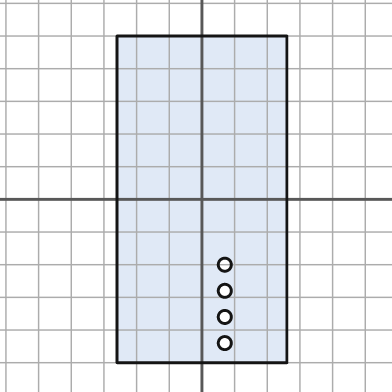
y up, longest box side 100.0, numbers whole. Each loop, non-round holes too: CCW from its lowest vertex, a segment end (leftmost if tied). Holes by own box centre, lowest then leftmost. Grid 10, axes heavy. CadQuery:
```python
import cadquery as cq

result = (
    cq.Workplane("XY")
    .moveTo(-26.0, -50.0)
    .lineTo(26.0, -50.0)
    .lineTo(26.0, 50.0)
    .lineTo(-26.0, 50.0)
    .close()
    .moveTo(7.0, -44.0)
    .circle(2.0)
    .moveTo(7.0, -36.0)
    .circle(2.0)
    .moveTo(7.0, -28.0)
    .circle(2.0)
    .moveTo(7.0, -20.0)
    .circle(2.0)
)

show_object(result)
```